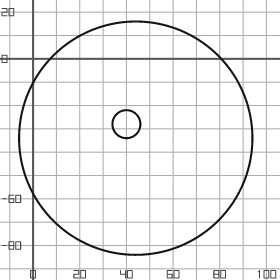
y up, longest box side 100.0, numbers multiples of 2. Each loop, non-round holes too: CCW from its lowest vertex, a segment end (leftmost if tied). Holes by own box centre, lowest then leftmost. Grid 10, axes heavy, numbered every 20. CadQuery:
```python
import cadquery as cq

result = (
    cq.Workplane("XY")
    .moveTo(44.0, -34.0)
    .circle(50.0)
    .moveTo(40.0, -28.0)
    .circle(6.0)
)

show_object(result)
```